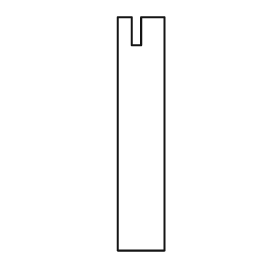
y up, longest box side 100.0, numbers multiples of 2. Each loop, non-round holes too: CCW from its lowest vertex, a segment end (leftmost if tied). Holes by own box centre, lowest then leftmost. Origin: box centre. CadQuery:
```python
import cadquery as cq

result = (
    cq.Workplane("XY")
    .moveTo(-10.0, -50.0)
    .lineTo(10.0, -50.0)
    .lineTo(10.0, 50.0)
    .lineTo(0.0, 50.0)
    .lineTo(0.0, 38.0)
    .lineTo(-4.0, 38.0)
    .lineTo(-4.0, 50.0)
    .lineTo(-10.0, 50.0)
    .close()
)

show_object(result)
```